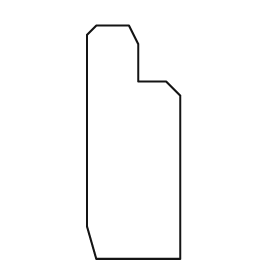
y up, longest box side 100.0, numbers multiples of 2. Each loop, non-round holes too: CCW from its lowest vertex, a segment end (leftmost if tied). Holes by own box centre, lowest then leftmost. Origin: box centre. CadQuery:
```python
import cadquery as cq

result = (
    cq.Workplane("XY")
    .moveTo(-16.0, -50.0)
    .lineTo(20.0, -50.0)
    .lineTo(20.0, 20.0)
    .lineTo(14.0, 26.0)
    .lineTo(2.0, 26.0)
    .lineTo(2.0, 42.0)
    .lineTo(-2.0, 50.0)
    .lineTo(-16.0, 50.0)
    .lineTo(-20.0, 46.0)
    .lineTo(-20.0, -36.0)
    .close()
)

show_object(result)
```